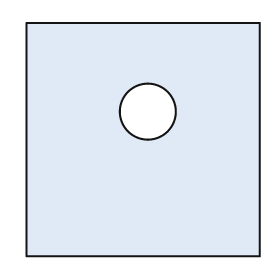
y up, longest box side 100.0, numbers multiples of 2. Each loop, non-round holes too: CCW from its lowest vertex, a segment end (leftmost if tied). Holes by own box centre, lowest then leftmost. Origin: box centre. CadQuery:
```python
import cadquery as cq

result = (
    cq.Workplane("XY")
    .moveTo(-50.0, -50.0)
    .lineTo(50.0, -50.0)
    .lineTo(50.0, 50.0)
    .lineTo(-50.0, 50.0)
    .close()
    .moveTo(2.0, 12.0)
    .circle(12.0)
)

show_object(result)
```